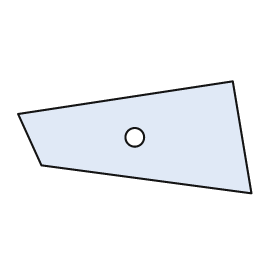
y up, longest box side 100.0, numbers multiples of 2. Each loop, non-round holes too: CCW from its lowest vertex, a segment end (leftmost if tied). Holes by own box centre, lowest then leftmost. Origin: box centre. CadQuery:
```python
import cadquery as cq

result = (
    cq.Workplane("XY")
    .moveTo(50.0, -24.0)
    .lineTo(42.0, 24.0)
    .lineTo(-50.0, 10.0)
    .lineTo(-40.0, -12.0)
    .close()
    .moveTo(0.0, 0.0)
    .circle(4.0)
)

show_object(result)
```